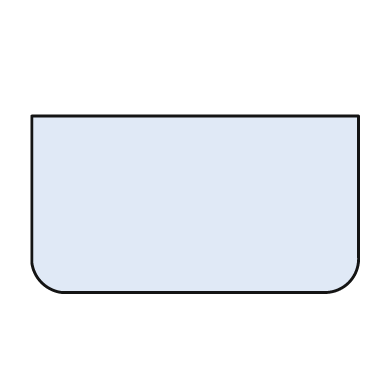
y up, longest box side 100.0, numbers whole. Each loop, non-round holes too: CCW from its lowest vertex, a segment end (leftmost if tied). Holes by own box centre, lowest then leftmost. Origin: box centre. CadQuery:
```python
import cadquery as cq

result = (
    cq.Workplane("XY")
    .moveTo(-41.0, -27.0)
    .lineTo(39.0, -27.0)
    .threePointArc((47.0, -24.0), (50.0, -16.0))
    .lineTo(50.0, 27.0)
    .lineTo(-50.0, 27.0)
    .lineTo(-50.0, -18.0)
    .threePointArc((-47.0, -24.0), (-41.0, -27.0))
    .close()
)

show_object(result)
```